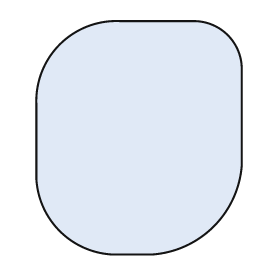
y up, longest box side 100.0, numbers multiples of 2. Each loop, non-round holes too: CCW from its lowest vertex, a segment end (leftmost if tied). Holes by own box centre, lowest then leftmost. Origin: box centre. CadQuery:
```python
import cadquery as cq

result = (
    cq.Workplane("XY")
    .moveTo(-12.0, -50.0)
    .lineTo(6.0, -50.0)
    .threePointArc((32.0, -38.0), (44.0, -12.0))
    .lineTo(44.0, 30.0)
    .threePointArc((38.0, 44.0), (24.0, 50.0))
    .lineTo(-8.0, 50.0)
    .threePointArc((-34.0, 40.0), (-44.0, 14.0))
    .lineTo(-44.0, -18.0)
    .threePointArc((-34.0, -40.0), (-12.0, -50.0))
    .close()
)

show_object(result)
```